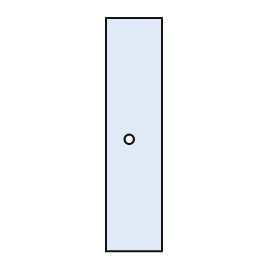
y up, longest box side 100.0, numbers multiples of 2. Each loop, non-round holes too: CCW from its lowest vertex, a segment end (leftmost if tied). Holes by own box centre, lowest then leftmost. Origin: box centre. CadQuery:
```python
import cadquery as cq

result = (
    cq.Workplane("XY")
    .moveTo(-12.0, -50.0)
    .lineTo(12.0, -50.0)
    .lineTo(12.0, 50.0)
    .lineTo(-12.0, 50.0)
    .close()
    .moveTo(-2.0, -2.0)
    .circle(2.0)
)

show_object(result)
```